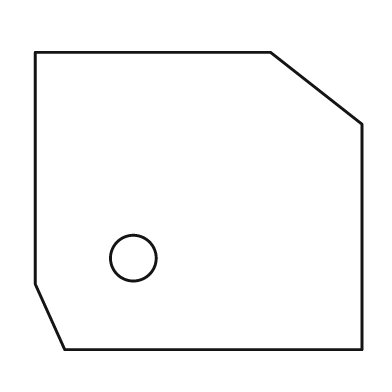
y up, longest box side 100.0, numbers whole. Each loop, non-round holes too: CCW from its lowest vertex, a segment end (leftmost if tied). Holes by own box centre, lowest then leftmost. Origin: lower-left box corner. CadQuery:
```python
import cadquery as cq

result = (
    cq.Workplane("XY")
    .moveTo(9.0, 0.0)
    .lineTo(100.0, 0.0)
    .lineTo(100.0, 69.0)
    .lineTo(72.0, 91.0)
    .lineTo(0.0, 91.0)
    .lineTo(0.0, 20.0)
    .close()
    .moveTo(30.0, 28.0)
    .circle(7.0)
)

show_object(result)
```